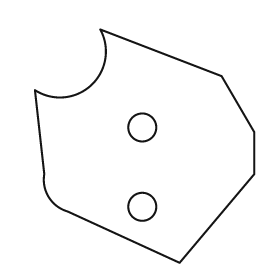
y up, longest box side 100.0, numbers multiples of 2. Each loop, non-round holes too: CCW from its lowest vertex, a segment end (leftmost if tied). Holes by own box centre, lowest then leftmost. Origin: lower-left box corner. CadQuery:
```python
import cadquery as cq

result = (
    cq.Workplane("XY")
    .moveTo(62.0, 0.0)
    .lineTo(94.0, 38.0)
    .lineTo(94.0, 56.0)
    .lineTo(80.0, 80.0)
    .lineTo(28.0, 100.0)
    .threePointArc((24.0, 76.0), (0.0, 74.0))
    .lineTo(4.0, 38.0)
    .threePointArc((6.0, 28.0), (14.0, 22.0))
    .close()
    .moveTo(46.0, 24.0)
    .circle(6.0)
    .moveTo(46.0, 58.0)
    .circle(6.0)
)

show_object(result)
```